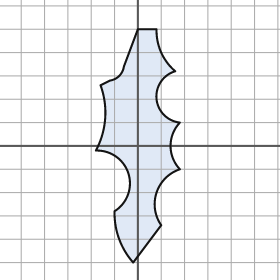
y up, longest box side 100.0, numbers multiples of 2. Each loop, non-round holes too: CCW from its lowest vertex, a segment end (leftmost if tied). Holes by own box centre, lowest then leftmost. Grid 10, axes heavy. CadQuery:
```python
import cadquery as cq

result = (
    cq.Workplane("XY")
    .moveTo(-2.0, -50.0)
    .lineTo(10.0, -34.0)
    .threePointArc((8.0, -20.0), (18.0, -10.0))
    .threePointArc((14.0, 0.0), (18.0, 10.0))
    .threePointArc((8.0, 20.0), (16.0, 32.0))
    .threePointArc((10.0, 40.0), (8.0, 50.0))
    .lineTo(0.0, 50.0)
    .lineTo(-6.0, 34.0)
    .threePointArc((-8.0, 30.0), (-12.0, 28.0))
    .lineTo(-16.0, 26.0)
    .threePointArc((-14.0, 12.0), (-18.0, -2.0))
    .threePointArc((-4.0, -12.0), (-10.0, -28.0))
    .threePointArc((-8.0, -40.0), (-2.0, -50.0))
    .close()
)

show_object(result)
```